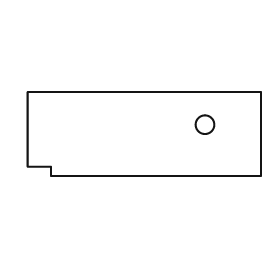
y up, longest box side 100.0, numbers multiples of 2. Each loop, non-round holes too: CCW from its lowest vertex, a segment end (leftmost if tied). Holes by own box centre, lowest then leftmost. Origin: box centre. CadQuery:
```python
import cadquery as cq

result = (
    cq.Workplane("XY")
    .moveTo(-40.0, -18.0)
    .lineTo(50.0, -18.0)
    .lineTo(50.0, 18.0)
    .lineTo(-50.0, 18.0)
    .lineTo(-50.0, -14.0)
    .lineTo(-40.0, -14.0)
    .close()
    .moveTo(26.0, 4.0)
    .circle(4.0)
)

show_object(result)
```